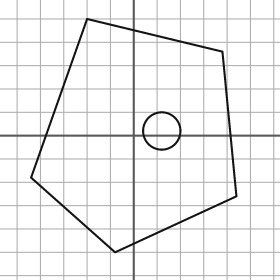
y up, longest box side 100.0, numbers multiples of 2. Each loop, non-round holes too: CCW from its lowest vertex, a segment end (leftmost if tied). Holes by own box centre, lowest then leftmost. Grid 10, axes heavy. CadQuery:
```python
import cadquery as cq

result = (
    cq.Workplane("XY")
    .moveTo(-8.0, -50.0)
    .lineTo(44.0, -26.0)
    .lineTo(38.0, 36.0)
    .lineTo(-20.0, 50.0)
    .lineTo(-44.0, -18.0)
    .close()
    .moveTo(12.0, 2.0)
    .circle(8.0)
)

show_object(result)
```